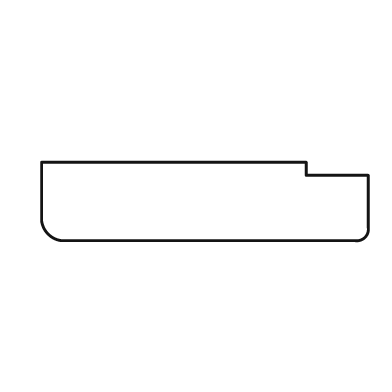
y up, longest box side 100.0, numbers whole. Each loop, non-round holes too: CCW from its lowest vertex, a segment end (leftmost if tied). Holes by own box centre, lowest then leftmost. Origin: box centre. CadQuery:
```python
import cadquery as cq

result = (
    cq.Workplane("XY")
    .moveTo(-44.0, -12.0)
    .lineTo(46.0, -12.0)
    .threePointArc((49.0, -11.0), (50.0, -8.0))
    .lineTo(50.0, 8.0)
    .lineTo(31.0, 8.0)
    .lineTo(31.0, 12.0)
    .lineTo(-50.0, 12.0)
    .lineTo(-50.0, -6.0)
    .threePointArc((-48.0, -10.0), (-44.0, -12.0))
    .close()
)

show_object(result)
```